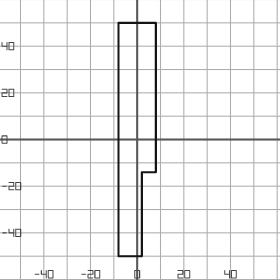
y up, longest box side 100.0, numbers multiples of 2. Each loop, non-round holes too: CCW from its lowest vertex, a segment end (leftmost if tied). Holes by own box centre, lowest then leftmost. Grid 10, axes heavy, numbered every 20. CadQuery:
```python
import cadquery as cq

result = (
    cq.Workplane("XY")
    .moveTo(-8.0, -50.0)
    .lineTo(2.0, -50.0)
    .lineTo(2.0, -14.0)
    .lineTo(8.0, -14.0)
    .lineTo(8.0, 50.0)
    .lineTo(-8.0, 50.0)
    .close()
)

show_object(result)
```